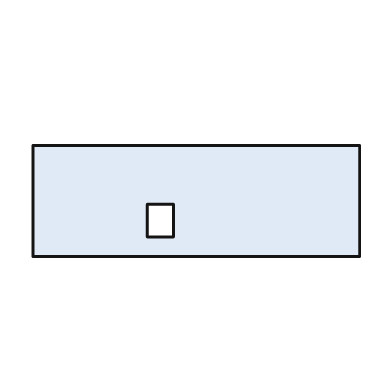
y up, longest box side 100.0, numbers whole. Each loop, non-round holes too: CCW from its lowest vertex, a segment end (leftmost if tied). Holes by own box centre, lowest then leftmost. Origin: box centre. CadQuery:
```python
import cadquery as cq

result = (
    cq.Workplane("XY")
    .moveTo(-50.0, -17.0)
    .lineTo(50.0, -17.0)
    .lineTo(50.0, 17.0)
    .lineTo(-50.0, 17.0)
    .close()
    .moveTo(-15.0, -11.0)
    .lineTo(-7.0, -11.0)
    .lineTo(-7.0, -1.0)
    .lineTo(-15.0, -1.0)
    .close()
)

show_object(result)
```